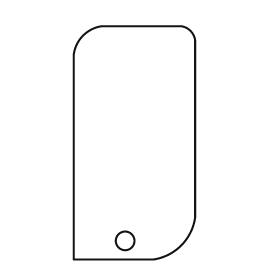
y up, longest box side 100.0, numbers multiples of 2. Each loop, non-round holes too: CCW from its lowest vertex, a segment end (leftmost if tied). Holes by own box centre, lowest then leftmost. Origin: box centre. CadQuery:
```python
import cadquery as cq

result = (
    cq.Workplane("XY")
    .moveTo(-26.0, -50.0)
    .lineTo(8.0, -50.0)
    .threePointArc((20.0, -44.0), (26.0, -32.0))
    .lineTo(26.0, 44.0)
    .threePointArc((24.0, 48.0), (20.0, 50.0))
    .lineTo(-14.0, 50.0)
    .threePointArc((-22.0, 46.0), (-26.0, 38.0))
    .close()
    .moveTo(-4.0, -42.0)
    .circle(4.0)
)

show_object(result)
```